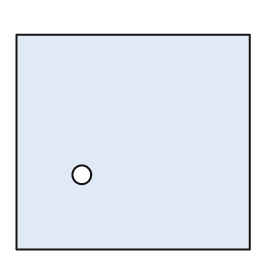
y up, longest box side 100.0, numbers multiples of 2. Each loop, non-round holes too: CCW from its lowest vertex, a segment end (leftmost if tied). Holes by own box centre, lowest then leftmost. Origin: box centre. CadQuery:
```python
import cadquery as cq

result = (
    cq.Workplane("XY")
    .moveTo(-50.0, -46.0)
    .lineTo(50.0, -46.0)
    .lineTo(50.0, 46.0)
    .lineTo(-50.0, 46.0)
    .close()
    .moveTo(-22.0, -14.0)
    .circle(4.0)
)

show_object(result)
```